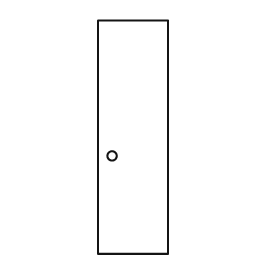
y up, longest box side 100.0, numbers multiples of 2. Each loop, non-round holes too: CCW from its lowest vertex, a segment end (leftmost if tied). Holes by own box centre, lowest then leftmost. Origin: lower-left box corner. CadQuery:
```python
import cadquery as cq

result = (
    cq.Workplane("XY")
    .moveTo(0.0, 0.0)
    .lineTo(30.0, 0.0)
    .lineTo(30.0, 100.0)
    .lineTo(0.0, 100.0)
    .close()
    .moveTo(6.0, 42.0)
    .circle(2.0)
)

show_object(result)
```